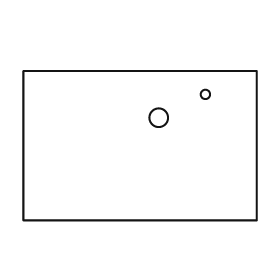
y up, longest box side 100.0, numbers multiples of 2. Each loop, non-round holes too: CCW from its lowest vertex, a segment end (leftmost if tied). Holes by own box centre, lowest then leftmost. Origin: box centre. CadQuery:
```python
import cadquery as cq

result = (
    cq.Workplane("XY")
    .moveTo(-50.0, -32.0)
    .lineTo(50.0, -32.0)
    .lineTo(50.0, 32.0)
    .lineTo(-50.0, 32.0)
    .close()
    .moveTo(8.0, 12.0)
    .circle(4.0)
    .moveTo(28.0, 22.0)
    .circle(2.0)
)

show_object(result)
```